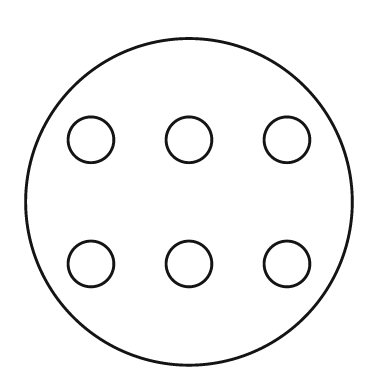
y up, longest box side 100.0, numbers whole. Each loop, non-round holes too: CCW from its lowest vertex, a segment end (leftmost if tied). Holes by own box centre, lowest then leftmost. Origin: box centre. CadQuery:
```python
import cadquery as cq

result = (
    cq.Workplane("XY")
    .moveTo(0.0, 0.0)
    .circle(50.0)
    .moveTo(-30.0, -19.0)
    .circle(7.0)
    .moveTo(0.0, -19.0)
    .circle(7.0)
    .moveTo(30.0, -19.0)
    .circle(7.0)
    .moveTo(-30.0, 19.0)
    .circle(7.0)
    .moveTo(0.0, 19.0)
    .circle(7.0)
    .moveTo(30.0, 19.0)
    .circle(7.0)
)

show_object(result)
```